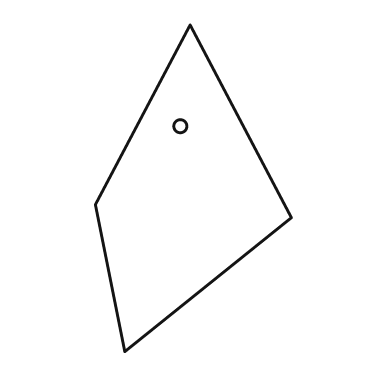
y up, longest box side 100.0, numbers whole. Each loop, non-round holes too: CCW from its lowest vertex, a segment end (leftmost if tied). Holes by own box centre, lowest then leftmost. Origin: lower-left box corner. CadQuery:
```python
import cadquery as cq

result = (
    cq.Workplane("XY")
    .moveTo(9.0, 0.0)
    .lineTo(60.0, 41.0)
    .lineTo(29.0, 100.0)
    .lineTo(0.0, 45.0)
    .close()
    .moveTo(26.0, 69.0)
    .circle(2.0)
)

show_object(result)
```